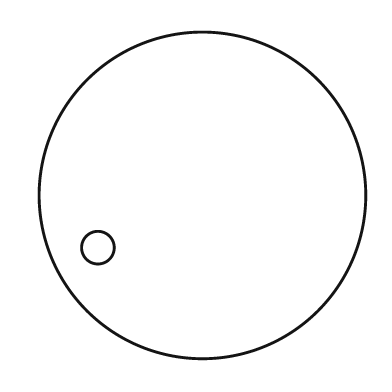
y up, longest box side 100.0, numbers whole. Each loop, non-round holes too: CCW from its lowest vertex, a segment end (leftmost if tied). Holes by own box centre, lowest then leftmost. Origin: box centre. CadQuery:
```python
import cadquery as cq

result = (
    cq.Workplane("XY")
    .moveTo(0.0, 0.0)
    .circle(50.0)
    .moveTo(-32.0, -16.0)
    .circle(5.0)
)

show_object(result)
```